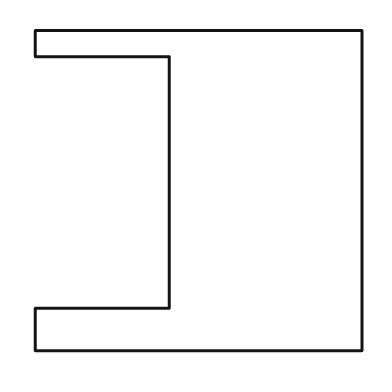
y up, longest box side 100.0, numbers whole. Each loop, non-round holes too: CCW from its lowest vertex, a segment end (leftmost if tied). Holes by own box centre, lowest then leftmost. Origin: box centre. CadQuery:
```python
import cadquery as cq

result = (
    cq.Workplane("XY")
    .moveTo(-50.0, -49.0)
    .lineTo(50.0, -49.0)
    .lineTo(50.0, 49.0)
    .lineTo(-50.0, 49.0)
    .lineTo(-50.0, 41.0)
    .lineTo(-9.0, 41.0)
    .lineTo(-9.0, -36.0)
    .lineTo(-50.0, -36.0)
    .close()
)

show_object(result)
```